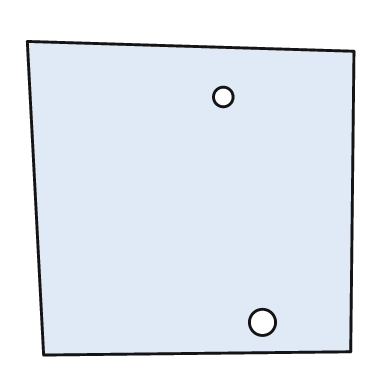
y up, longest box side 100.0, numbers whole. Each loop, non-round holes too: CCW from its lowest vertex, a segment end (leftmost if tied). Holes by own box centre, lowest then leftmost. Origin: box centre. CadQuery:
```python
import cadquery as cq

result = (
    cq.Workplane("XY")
    .moveTo(-45.0, -48.0)
    .lineTo(49.0, -47.0)
    .lineTo(50.0, 45.0)
    .lineTo(-50.0, 48.0)
    .close()
    .moveTo(22.0, -38.0)
    .circle(4.0)
    .moveTo(10.0, 31.0)
    .circle(3.0)
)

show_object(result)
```